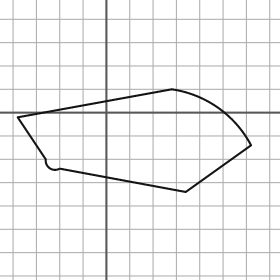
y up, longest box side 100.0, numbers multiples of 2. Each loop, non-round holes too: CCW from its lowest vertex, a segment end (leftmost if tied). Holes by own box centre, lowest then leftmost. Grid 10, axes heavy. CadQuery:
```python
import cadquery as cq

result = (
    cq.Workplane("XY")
    .moveTo(34.0, -34.0)
    .lineTo(62.0, -14.0)
    .threePointArc((48.0, 2.0), (28.0, 10.0))
    .lineTo(-38.0, -2.0)
    .lineTo(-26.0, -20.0)
    .threePointArc((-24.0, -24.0), (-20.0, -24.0))
    .close()
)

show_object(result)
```